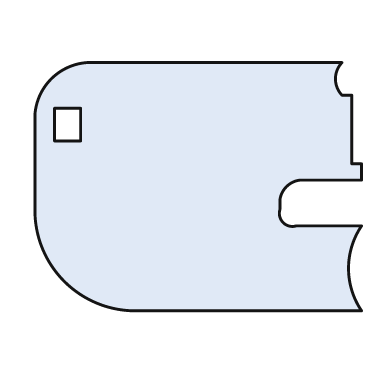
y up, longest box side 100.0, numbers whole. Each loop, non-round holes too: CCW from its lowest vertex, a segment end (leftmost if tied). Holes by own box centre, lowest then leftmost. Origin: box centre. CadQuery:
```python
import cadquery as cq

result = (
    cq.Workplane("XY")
    .moveTo(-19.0, -38.0)
    .lineTo(50.0, -38.0)
    .threePointArc((46.0, -25.0), (50.0, -12.0))
    .lineTo(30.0, -12.0)
    .threePointArc((26.0, -11.0), (25.0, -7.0))
    .lineTo(25.0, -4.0)
    .threePointArc((27.0, 0.0), (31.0, 2.0))
    .lineTo(50.0, 2.0)
    .lineTo(50.0, 7.0)
    .lineTo(47.0, 7.0)
    .lineTo(47.0, 28.0)
    .lineTo(44.0, 28.0)
    .threePointArc((42.0, 33.0), (44.0, 38.0))
    .lineTo(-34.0, 38.0)
    .threePointArc((-45.0, 33.0), (-50.0, 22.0))
    .lineTo(-50.0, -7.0)
    .threePointArc((-41.0, -29.0), (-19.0, -38.0))
    .close()
    .moveTo(-44.0, 14.0)
    .lineTo(-36.0, 14.0)
    .lineTo(-36.0, 24.0)
    .lineTo(-44.0, 24.0)
    .close()
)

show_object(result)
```